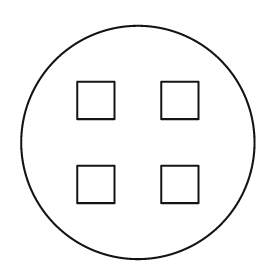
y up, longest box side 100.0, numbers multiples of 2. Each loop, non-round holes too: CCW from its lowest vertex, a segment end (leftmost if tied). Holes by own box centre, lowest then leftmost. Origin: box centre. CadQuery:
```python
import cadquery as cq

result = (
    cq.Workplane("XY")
    .moveTo(0.0, 0.0)
    .circle(50.0)
    .moveTo(-26.0, -26.0)
    .lineTo(-10.0, -26.0)
    .lineTo(-10.0, -10.0)
    .lineTo(-26.0, -10.0)
    .close()
    .moveTo(10.0, -26.0)
    .lineTo(26.0, -26.0)
    .lineTo(26.0, -10.0)
    .lineTo(10.0, -10.0)
    .close()
    .moveTo(-26.0, 10.0)
    .lineTo(-10.0, 10.0)
    .lineTo(-10.0, 26.0)
    .lineTo(-26.0, 26.0)
    .close()
    .moveTo(10.0, 10.0)
    .lineTo(26.0, 10.0)
    .lineTo(26.0, 26.0)
    .lineTo(10.0, 26.0)
    .close()
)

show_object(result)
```